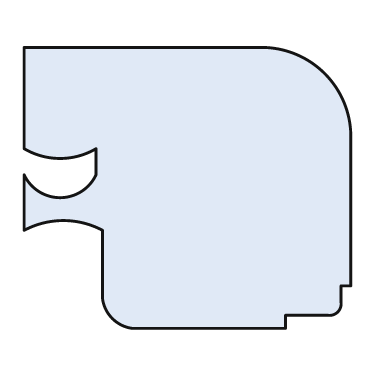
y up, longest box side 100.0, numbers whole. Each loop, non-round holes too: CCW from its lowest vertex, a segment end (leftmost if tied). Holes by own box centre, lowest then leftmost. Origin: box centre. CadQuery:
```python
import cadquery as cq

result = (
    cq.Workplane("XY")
    .moveTo(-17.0, -43.0)
    .lineTo(30.0, -43.0)
    .lineTo(30.0, -39.0)
    .lineTo(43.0, -39.0)
    .threePointArc((46.0, -38.0), (47.0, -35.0))
    .lineTo(47.0, -30.0)
    .lineTo(50.0, -30.0)
    .lineTo(50.0, 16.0)
    .threePointArc((42.0, 35.0), (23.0, 43.0))
    .lineTo(-50.0, 43.0)
    .lineTo(-50.0, 12.0)
    .threePointArc((-39.0, 9.0), (-28.0, 12.0))
    .lineTo(-28.0, 4.0)
    .threePointArc((-39.0, -3.0), (-50.0, 4.0))
    .lineTo(-50.0, -13.0)
    .threePointArc((-38.0, -10.0), (-26.0, -13.0))
    .lineTo(-26.0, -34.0)
    .threePointArc((-23.0, -40.0), (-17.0, -43.0))
    .close()
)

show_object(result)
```